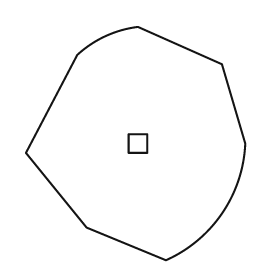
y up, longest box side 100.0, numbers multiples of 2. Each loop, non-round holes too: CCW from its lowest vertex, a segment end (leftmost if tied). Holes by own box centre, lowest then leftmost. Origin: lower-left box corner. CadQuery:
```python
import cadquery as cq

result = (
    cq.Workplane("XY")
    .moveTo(60.0, 0.0)
    .threePointArc((84.0, 20.0), (94.0, 50.0))
    .lineTo(84.0, 84.0)
    .lineTo(48.0, 100.0)
    .threePointArc((34.0, 96.0), (22.0, 88.0))
    .lineTo(0.0, 46.0)
    .lineTo(26.0, 14.0)
    .close()
    .moveTo(44.0, 46.0)
    .lineTo(52.0, 46.0)
    .lineTo(52.0, 54.0)
    .lineTo(44.0, 54.0)
    .close()
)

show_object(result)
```